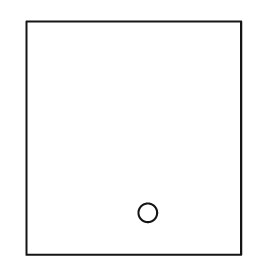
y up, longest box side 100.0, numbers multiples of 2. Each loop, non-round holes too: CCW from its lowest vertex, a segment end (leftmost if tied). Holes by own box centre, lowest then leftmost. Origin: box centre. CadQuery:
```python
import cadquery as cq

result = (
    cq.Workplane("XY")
    .moveTo(-46.0, -50.0)
    .lineTo(46.0, -50.0)
    .lineTo(46.0, 50.0)
    .lineTo(-46.0, 50.0)
    .close()
    .moveTo(6.0, -32.0)
    .circle(4.0)
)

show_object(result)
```